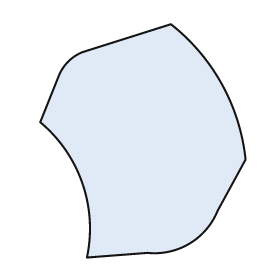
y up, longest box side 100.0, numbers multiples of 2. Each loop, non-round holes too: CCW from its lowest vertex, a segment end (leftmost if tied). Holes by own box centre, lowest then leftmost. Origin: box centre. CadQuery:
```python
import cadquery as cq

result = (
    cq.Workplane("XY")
    .moveTo(-24.0, -50.0)
    .lineTo(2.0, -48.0)
    .threePointArc((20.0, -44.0), (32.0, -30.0))
    .lineTo(44.0, -8.0)
    .threePointArc((34.0, 24.0), (12.0, 50.0))
    .lineTo(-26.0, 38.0)
    .threePointArc((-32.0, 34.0), (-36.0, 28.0))
    .lineTo(-44.0, 8.0)
    .threePointArc((-26.0, -18.0), (-24.0, -50.0))
    .close()
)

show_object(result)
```